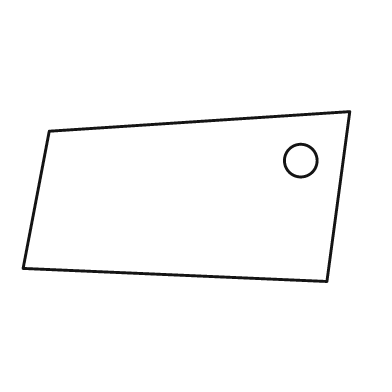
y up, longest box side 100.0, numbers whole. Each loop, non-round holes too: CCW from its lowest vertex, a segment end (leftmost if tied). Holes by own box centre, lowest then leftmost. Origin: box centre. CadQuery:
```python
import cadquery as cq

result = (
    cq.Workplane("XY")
    .moveTo(43.0, -26.0)
    .lineTo(50.0, 26.0)
    .lineTo(-42.0, 20.0)
    .lineTo(-50.0, -22.0)
    .close()
    .moveTo(35.0, 11.0)
    .circle(5.0)
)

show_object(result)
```